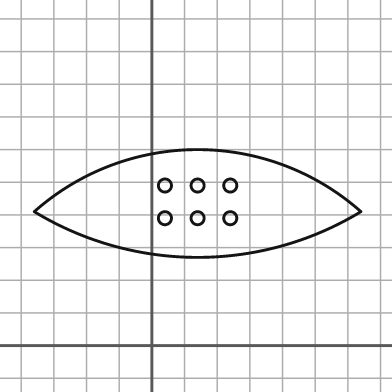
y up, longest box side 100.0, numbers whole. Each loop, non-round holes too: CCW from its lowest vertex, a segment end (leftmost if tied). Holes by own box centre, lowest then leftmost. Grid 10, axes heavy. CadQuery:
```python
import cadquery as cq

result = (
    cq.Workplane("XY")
    .moveTo(-36.0, 41.0)
    .threePointArc((14.0, 27.0), (64.0, 41.0))
    .threePointArc((14.0, 60.0), (-36.0, 41.0))
    .close()
    .moveTo(4.0, 39.0)
    .circle(2.0)
    .moveTo(14.0, 39.0)
    .circle(2.0)
    .moveTo(24.0, 39.0)
    .circle(2.0)
    .moveTo(4.0, 49.0)
    .circle(2.0)
    .moveTo(14.0, 49.0)
    .circle(2.0)
    .moveTo(24.0, 49.0)
    .circle(2.0)
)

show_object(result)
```